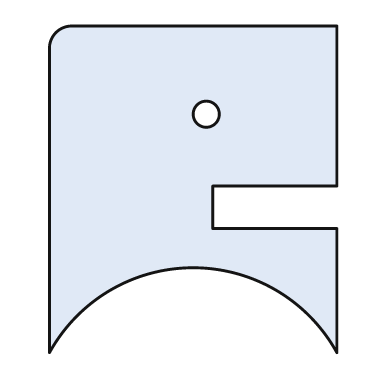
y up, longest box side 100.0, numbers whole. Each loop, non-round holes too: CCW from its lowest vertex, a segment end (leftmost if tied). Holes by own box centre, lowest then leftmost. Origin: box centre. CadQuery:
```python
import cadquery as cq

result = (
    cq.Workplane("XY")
    .moveTo(-44.0, -50.0)
    .threePointArc((0.0, -24.0), (44.0, -50.0))
    .lineTo(44.0, -12.0)
    .lineTo(6.0, -12.0)
    .lineTo(6.0, 1.0)
    .lineTo(44.0, 1.0)
    .lineTo(44.0, 50.0)
    .lineTo(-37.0, 50.0)
    .threePointArc((-42.0, 48.0), (-44.0, 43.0))
    .close()
    .moveTo(4.0, 23.0)
    .circle(4.0)
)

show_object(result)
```